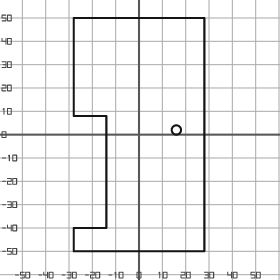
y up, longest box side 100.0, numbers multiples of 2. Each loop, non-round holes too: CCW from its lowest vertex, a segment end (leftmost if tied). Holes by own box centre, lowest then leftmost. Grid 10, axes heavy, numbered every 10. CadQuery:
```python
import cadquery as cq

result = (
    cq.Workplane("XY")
    .moveTo(-28.0, -50.0)
    .lineTo(28.0, -50.0)
    .lineTo(28.0, 50.0)
    .lineTo(-28.0, 50.0)
    .lineTo(-28.0, 8.0)
    .lineTo(-14.0, 8.0)
    .lineTo(-14.0, -40.0)
    .lineTo(-28.0, -40.0)
    .close()
    .moveTo(16.0, 2.0)
    .circle(2.0)
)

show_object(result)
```